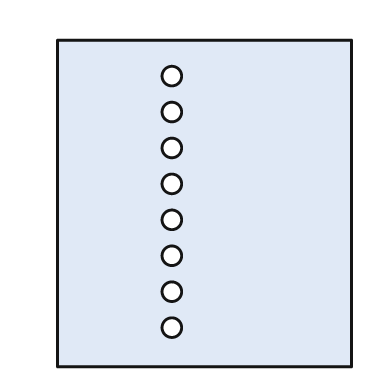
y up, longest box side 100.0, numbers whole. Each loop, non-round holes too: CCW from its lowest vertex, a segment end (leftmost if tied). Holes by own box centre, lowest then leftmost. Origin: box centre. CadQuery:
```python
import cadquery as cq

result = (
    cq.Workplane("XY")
    .moveTo(-45.0, -50.0)
    .lineTo(45.0, -50.0)
    .lineTo(45.0, 50.0)
    .lineTo(-45.0, 50.0)
    .close()
    .moveTo(-10.0, -38.0)
    .circle(3.0)
    .moveTo(-10.0, -27.0)
    .circle(3.0)
    .moveTo(-10.0, -16.0)
    .circle(3.0)
    .moveTo(-10.0, -5.0)
    .circle(3.0)
    .moveTo(-10.0, 6.0)
    .circle(3.0)
    .moveTo(-10.0, 17.0)
    .circle(3.0)
    .moveTo(-10.0, 28.0)
    .circle(3.0)
    .moveTo(-10.0, 39.0)
    .circle(3.0)
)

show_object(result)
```